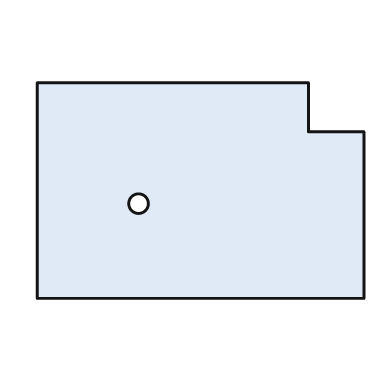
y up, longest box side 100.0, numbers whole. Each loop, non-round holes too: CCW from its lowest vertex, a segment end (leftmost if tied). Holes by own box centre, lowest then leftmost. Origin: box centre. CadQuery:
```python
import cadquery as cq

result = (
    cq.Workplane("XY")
    .moveTo(-50.0, -33.0)
    .lineTo(50.0, -33.0)
    .lineTo(50.0, 18.0)
    .lineTo(33.0, 18.0)
    .lineTo(33.0, 33.0)
    .lineTo(-50.0, 33.0)
    .close()
    .moveTo(-19.0, -4.0)
    .circle(3.0)
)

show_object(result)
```